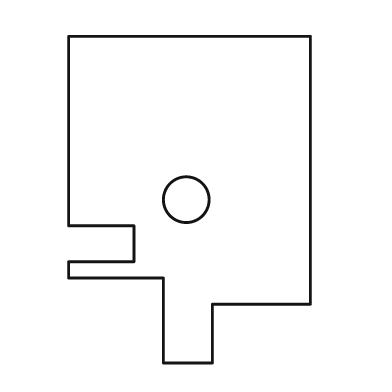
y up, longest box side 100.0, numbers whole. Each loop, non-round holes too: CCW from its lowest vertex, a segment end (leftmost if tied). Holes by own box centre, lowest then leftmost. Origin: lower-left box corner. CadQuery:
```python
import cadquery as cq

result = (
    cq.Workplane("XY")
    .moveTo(29.0, 0.0)
    .lineTo(44.0, 0.0)
    .lineTo(44.0, 18.0)
    .lineTo(74.0, 18.0)
    .lineTo(74.0, 100.0)
    .lineTo(0.0, 100.0)
    .lineTo(0.0, 42.0)
    .lineTo(20.0, 42.0)
    .lineTo(20.0, 31.0)
    .lineTo(0.0, 31.0)
    .lineTo(0.0, 26.0)
    .lineTo(29.0, 26.0)
    .close()
    .moveTo(36.0, 50.0)
    .circle(7.0)
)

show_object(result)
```